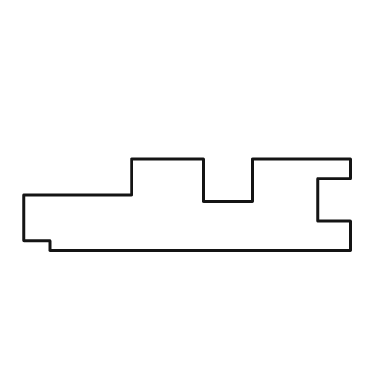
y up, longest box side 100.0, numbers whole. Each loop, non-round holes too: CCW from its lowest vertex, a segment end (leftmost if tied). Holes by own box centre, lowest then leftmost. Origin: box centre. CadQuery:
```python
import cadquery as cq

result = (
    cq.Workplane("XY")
    .moveTo(-42.0, -14.0)
    .lineTo(50.0, -14.0)
    .lineTo(50.0, -5.0)
    .lineTo(40.0, -5.0)
    .lineTo(40.0, 8.0)
    .lineTo(50.0, 8.0)
    .lineTo(50.0, 14.0)
    .lineTo(20.0, 14.0)
    .lineTo(20.0, 1.0)
    .lineTo(5.0, 1.0)
    .lineTo(5.0, 14.0)
    .lineTo(-17.0, 14.0)
    .lineTo(-17.0, 3.0)
    .lineTo(-50.0, 3.0)
    .lineTo(-50.0, -11.0)
    .lineTo(-42.0, -11.0)
    .close()
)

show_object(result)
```